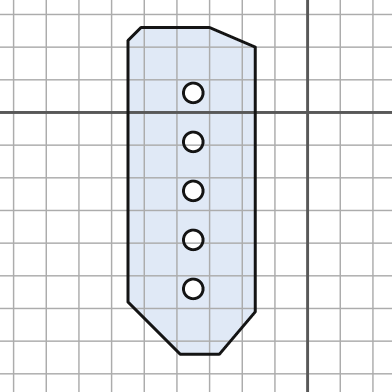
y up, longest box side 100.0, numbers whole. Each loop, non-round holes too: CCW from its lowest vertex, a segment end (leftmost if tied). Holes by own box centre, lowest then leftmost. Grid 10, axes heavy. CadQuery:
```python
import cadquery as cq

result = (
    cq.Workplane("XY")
    .moveTo(-39.0, -74.0)
    .lineTo(-27.0, -74.0)
    .lineTo(-16.0, -61.0)
    .lineTo(-16.0, 20.0)
    .lineTo(-30.0, 26.0)
    .lineTo(-51.0, 26.0)
    .lineTo(-55.0, 22.0)
    .lineTo(-55.0, -58.0)
    .close()
    .moveTo(-35.0, -54.0)
    .circle(3.0)
    .moveTo(-35.0, -39.0)
    .circle(3.0)
    .moveTo(-35.0, -24.0)
    .circle(3.0)
    .moveTo(-35.0, -9.0)
    .circle(3.0)
    .moveTo(-35.0, 6.0)
    .circle(3.0)
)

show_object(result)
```